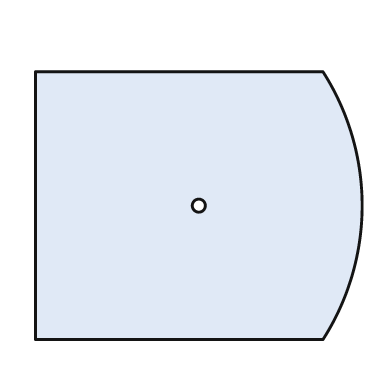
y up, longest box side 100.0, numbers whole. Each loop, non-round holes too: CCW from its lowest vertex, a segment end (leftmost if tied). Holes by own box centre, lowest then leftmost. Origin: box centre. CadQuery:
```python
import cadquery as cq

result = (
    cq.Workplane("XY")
    .moveTo(-50.0, -41.0)
    .lineTo(38.0, -41.0)
    .threePointArc((50.0, 0.0), (38.0, 41.0))
    .lineTo(-50.0, 41.0)
    .close()
    .moveTo(0.0, 0.0)
    .circle(2.0)
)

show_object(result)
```